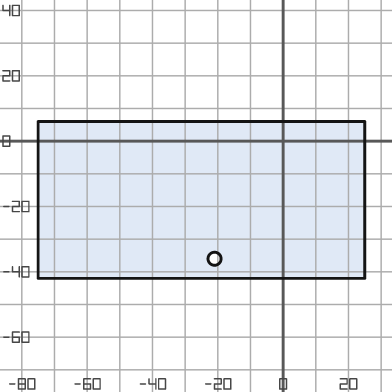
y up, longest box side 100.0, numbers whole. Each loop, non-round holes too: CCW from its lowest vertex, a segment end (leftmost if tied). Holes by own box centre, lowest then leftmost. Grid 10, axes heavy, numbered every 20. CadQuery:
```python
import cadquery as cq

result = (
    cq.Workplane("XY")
    .moveTo(-75.0, -42.0)
    .lineTo(25.0, -42.0)
    .lineTo(25.0, 6.0)
    .lineTo(-75.0, 6.0)
    .close()
    .moveTo(-21.0, -36.0)
    .circle(2.0)
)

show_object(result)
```